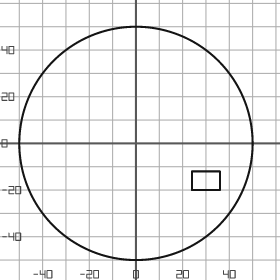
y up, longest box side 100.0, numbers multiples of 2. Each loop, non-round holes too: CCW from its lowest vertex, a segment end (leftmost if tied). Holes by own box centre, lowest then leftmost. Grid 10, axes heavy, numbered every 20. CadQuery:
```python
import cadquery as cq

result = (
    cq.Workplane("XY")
    .moveTo(0.0, 0.0)
    .circle(50.0)
    .moveTo(24.0, -20.0)
    .lineTo(36.0, -20.0)
    .lineTo(36.0, -12.0)
    .lineTo(24.0, -12.0)
    .close()
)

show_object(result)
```